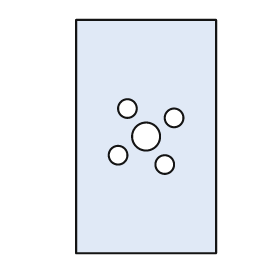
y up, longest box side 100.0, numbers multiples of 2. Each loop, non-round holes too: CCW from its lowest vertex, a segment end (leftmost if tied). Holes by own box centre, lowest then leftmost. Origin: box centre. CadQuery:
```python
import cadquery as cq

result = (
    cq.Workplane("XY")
    .moveTo(-30.0, -50.0)
    .lineTo(30.0, -50.0)
    .lineTo(30.0, 50.0)
    .lineTo(-30.0, 50.0)
    .close()
    .moveTo(8.0, -12.0)
    .circle(4.0)
    .moveTo(-12.0, -8.0)
    .circle(4.0)
    .moveTo(0.0, 0.0)
    .circle(6.0)
    .moveTo(12.0, 8.0)
    .circle(4.0)
    .moveTo(-8.0, 12.0)
    .circle(4.0)
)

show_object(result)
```